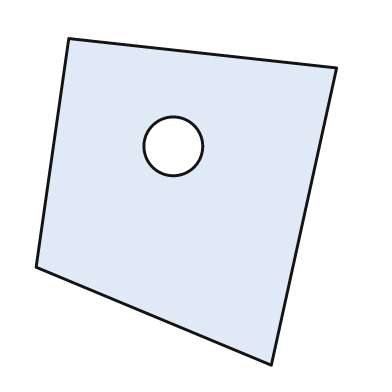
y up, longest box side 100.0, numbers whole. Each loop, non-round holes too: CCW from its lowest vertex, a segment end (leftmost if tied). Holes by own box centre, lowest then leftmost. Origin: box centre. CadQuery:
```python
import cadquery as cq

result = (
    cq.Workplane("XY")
    .moveTo(26.0, -50.0)
    .lineTo(46.0, 41.0)
    .lineTo(-36.0, 50.0)
    .lineTo(-46.0, -20.0)
    .close()
    .moveTo(-4.0, 17.0)
    .circle(9.0)
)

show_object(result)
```